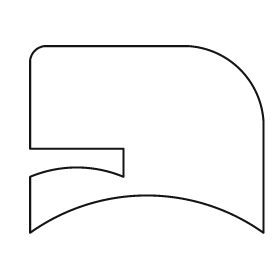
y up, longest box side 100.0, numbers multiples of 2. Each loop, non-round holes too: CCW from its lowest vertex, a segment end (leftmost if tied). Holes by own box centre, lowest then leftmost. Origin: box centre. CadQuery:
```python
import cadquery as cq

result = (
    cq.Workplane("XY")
    .moveTo(-50.0, -40.0)
    .threePointArc((0.0, -24.0), (50.0, -40.0))
    .lineTo(50.0, 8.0)
    .threePointArc((40.0, 30.0), (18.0, 40.0))
    .lineTo(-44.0, 40.0)
    .threePointArc((-48.0, 38.0), (-50.0, 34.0))
    .lineTo(-50.0, -4.0)
    .lineTo(-10.0, -4.0)
    .lineTo(-10.0, -16.0)
    .threePointArc((-30.0, -12.0), (-50.0, -16.0))
    .close()
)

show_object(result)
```